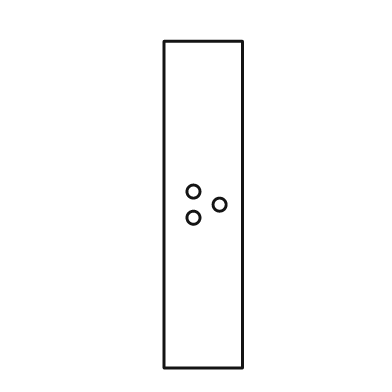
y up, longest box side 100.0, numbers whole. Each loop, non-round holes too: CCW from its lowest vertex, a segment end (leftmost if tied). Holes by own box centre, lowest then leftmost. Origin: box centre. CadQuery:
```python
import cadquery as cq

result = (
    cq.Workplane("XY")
    .moveTo(-12.0, -50.0)
    .lineTo(12.0, -50.0)
    .lineTo(12.0, 50.0)
    .lineTo(-12.0, 50.0)
    .close()
    .moveTo(-3.0, -4.0)
    .circle(2.0)
    .moveTo(5.0, 0.0)
    .circle(2.0)
    .moveTo(-3.0, 4.0)
    .circle(2.0)
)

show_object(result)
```